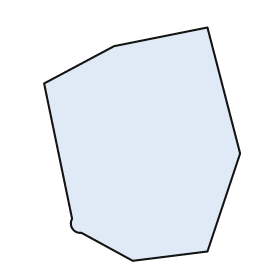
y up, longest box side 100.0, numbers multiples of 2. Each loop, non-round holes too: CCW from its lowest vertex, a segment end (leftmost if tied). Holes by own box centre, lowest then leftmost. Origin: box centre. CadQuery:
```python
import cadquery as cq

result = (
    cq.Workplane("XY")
    .moveTo(-4.0, -50.0)
    .lineTo(28.0, -46.0)
    .lineTo(42.0, -4.0)
    .lineTo(28.0, 50.0)
    .lineTo(-12.0, 42.0)
    .lineTo(-42.0, 26.0)
    .lineTo(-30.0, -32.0)
    .threePointArc((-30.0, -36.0), (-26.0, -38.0))
    .close()
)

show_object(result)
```